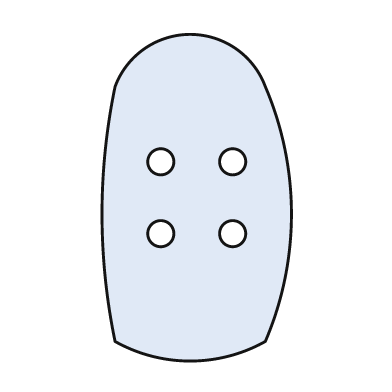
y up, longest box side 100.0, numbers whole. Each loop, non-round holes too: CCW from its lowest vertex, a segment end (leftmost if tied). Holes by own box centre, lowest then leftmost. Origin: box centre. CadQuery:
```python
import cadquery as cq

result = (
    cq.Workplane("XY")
    .moveTo(-25.0, -44.0)
    .threePointArc((-2.0, -50.0), (21.0, -44.0))
    .threePointArc((29.0, -5.0), (21.0, 34.0))
    .threePointArc((-2.0, 50.0), (-25.0, 34.0))
    .threePointArc((-29.0, -5.0), (-25.0, -44.0))
    .close()
    .moveTo(-11.0, -11.0)
    .circle(4.0)
    .moveTo(11.0, -11.0)
    .circle(4.0)
    .moveTo(-11.0, 11.0)
    .circle(4.0)
    .moveTo(11.0, 11.0)
    .circle(4.0)
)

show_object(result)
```